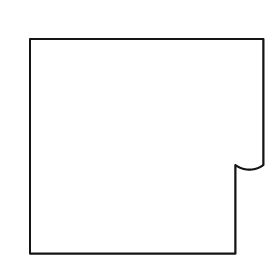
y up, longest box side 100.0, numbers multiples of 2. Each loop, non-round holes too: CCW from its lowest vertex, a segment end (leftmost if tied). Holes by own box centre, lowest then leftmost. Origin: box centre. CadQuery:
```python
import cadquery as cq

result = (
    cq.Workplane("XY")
    .moveTo(-50.0, -46.0)
    .lineTo(38.0, -46.0)
    .lineTo(38.0, -8.0)
    .threePointArc((44.0, -10.0), (50.0, -8.0))
    .lineTo(50.0, 46.0)
    .lineTo(-50.0, 46.0)
    .close()
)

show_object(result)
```